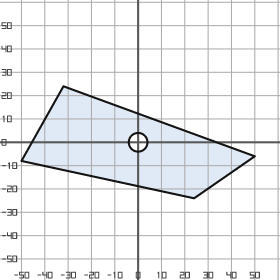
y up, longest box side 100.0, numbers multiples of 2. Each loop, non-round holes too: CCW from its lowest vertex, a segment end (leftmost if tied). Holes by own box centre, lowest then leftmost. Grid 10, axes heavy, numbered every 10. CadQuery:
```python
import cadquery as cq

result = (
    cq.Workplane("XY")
    .moveTo(24.0, -24.0)
    .lineTo(50.0, -6.0)
    .lineTo(-32.0, 24.0)
    .lineTo(-50.0, -8.0)
    .close()
    .moveTo(0.0, 0.0)
    .circle(4.0)
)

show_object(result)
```